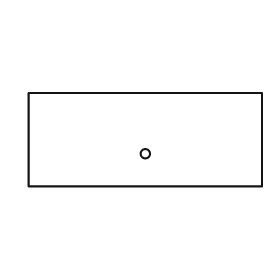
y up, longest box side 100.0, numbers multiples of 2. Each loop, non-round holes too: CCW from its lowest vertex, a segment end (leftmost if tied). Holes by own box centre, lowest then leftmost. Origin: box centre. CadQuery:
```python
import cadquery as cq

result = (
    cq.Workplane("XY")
    .moveTo(-50.0, -20.0)
    .lineTo(50.0, -20.0)
    .lineTo(50.0, 20.0)
    .lineTo(-50.0, 20.0)
    .close()
    .moveTo(0.0, -6.0)
    .circle(2.0)
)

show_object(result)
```